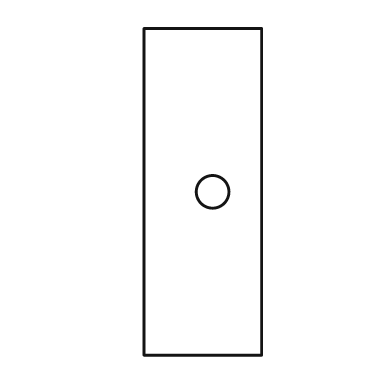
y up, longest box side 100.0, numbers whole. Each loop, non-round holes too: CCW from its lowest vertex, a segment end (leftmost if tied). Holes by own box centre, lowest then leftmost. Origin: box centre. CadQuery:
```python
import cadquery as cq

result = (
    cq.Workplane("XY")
    .moveTo(-18.0, -50.0)
    .lineTo(18.0, -50.0)
    .lineTo(18.0, 50.0)
    .lineTo(-18.0, 50.0)
    .close()
    .moveTo(3.0, 0.0)
    .circle(5.0)
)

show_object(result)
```